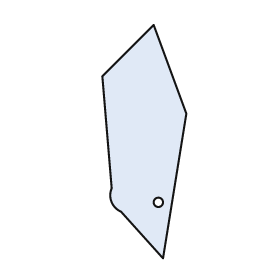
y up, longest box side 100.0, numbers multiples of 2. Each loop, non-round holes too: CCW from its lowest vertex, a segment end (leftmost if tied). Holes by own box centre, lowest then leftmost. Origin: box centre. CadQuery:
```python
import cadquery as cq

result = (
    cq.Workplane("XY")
    .moveTo(8.0, -50.0)
    .lineTo(18.0, 12.0)
    .lineTo(4.0, 50.0)
    .lineTo(-18.0, 28.0)
    .lineTo(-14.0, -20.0)
    .threePointArc((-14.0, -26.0), (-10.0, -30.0))
    .close()
    .moveTo(6.0, -26.0)
    .circle(2.0)
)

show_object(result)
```